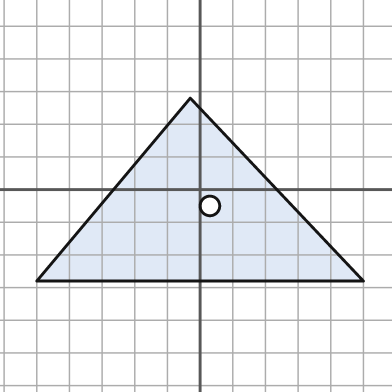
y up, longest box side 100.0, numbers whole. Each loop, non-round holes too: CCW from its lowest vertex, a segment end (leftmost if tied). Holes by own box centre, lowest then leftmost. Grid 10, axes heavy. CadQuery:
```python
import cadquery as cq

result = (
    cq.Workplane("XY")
    .moveTo(-50.0, -28.0)
    .lineTo(50.0, -28.0)
    .lineTo(-3.0, 28.0)
    .close()
    .moveTo(3.0, -5.0)
    .circle(3.0)
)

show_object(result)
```